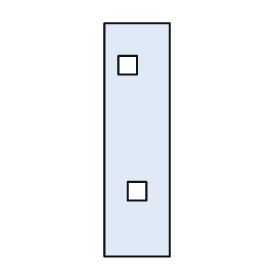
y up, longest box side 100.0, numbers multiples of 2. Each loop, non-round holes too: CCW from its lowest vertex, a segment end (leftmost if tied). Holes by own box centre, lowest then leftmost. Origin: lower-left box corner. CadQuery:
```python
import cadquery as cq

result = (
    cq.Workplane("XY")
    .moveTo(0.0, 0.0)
    .lineTo(28.0, 0.0)
    .lineTo(28.0, 100.0)
    .lineTo(0.0, 100.0)
    .close()
    .moveTo(10.0, 24.0)
    .lineTo(18.0, 24.0)
    .lineTo(18.0, 32.0)
    .lineTo(10.0, 32.0)
    .close()
    .moveTo(6.0, 78.0)
    .lineTo(14.0, 78.0)
    .lineTo(14.0, 86.0)
    .lineTo(6.0, 86.0)
    .close()
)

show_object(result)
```